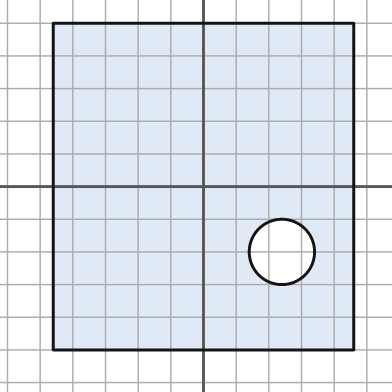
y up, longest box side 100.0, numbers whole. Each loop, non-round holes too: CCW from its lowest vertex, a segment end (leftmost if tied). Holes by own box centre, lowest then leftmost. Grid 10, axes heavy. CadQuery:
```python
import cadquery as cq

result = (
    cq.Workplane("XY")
    .moveTo(-46.0, -50.0)
    .lineTo(46.0, -50.0)
    .lineTo(46.0, 50.0)
    .lineTo(-46.0, 50.0)
    .close()
    .moveTo(24.0, -20.0)
    .circle(10.0)
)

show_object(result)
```